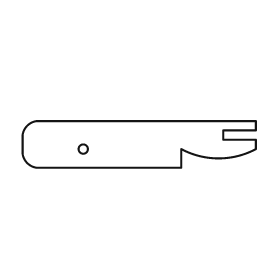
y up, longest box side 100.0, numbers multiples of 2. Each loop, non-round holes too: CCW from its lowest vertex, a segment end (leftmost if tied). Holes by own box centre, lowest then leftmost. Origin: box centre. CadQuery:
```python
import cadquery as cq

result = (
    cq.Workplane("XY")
    .moveTo(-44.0, -10.0)
    .lineTo(18.0, -10.0)
    .lineTo(18.0, -2.0)
    .threePointArc((34.0, -6.0), (50.0, -2.0))
    .lineTo(50.0, 2.0)
    .lineTo(36.0, 2.0)
    .lineTo(36.0, 6.0)
    .lineTo(50.0, 6.0)
    .lineTo(50.0, 10.0)
    .lineTo(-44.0, 10.0)
    .threePointArc((-48.0, 8.0), (-50.0, 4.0))
    .lineTo(-50.0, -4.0)
    .threePointArc((-48.0, -8.0), (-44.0, -10.0))
    .close()
    .moveTo(-24.0, -2.0)
    .circle(2.0)
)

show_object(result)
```